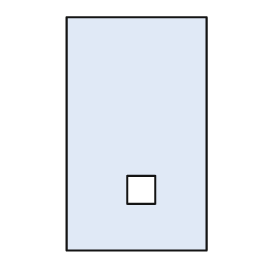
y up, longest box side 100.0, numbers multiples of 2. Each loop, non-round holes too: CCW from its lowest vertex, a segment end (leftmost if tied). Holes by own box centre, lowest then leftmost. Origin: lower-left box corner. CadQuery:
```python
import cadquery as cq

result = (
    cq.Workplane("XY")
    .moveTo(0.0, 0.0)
    .lineTo(60.0, 0.0)
    .lineTo(60.0, 100.0)
    .lineTo(0.0, 100.0)
    .close()
    .moveTo(26.0, 20.0)
    .lineTo(38.0, 20.0)
    .lineTo(38.0, 32.0)
    .lineTo(26.0, 32.0)
    .close()
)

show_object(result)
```